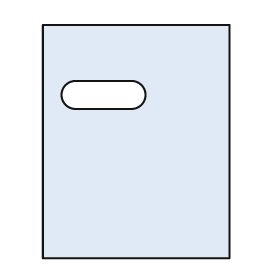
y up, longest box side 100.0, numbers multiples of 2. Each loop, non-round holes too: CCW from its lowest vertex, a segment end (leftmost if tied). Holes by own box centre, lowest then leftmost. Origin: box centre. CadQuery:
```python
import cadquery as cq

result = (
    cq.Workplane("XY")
    .moveTo(-40.0, -50.0)
    .lineTo(40.0, -50.0)
    .lineTo(40.0, 50.0)
    .lineTo(-40.0, 50.0)
    .close()
    .moveTo(-26.0, 14.0)
    .lineTo(-2.0, 14.0)
    .threePointArc((4.0, 20.0), (-2.0, 26.0))
    .lineTo(-26.0, 26.0)
    .threePointArc((-32.0, 20.0), (-26.0, 14.0))
    .close()
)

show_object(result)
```